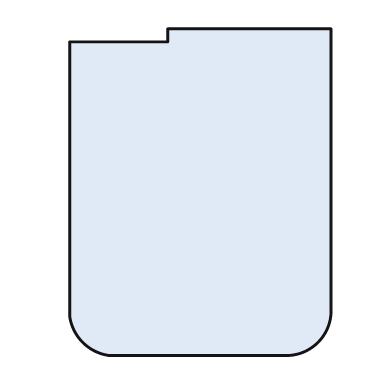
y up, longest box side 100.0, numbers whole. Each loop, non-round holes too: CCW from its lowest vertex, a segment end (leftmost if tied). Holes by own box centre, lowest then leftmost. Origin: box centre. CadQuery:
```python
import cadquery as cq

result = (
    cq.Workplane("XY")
    .moveTo(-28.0, -50.0)
    .lineTo(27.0, -50.0)
    .threePointArc((36.0, -46.0), (40.0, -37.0))
    .lineTo(40.0, 50.0)
    .lineTo(-10.0, 50.0)
    .lineTo(-10.0, 46.0)
    .lineTo(-40.0, 46.0)
    .lineTo(-40.0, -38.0)
    .threePointArc((-36.0, -46.0), (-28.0, -50.0))
    .close()
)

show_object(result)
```